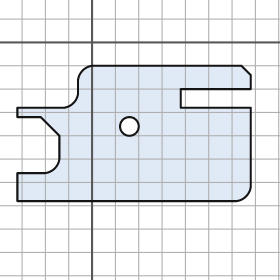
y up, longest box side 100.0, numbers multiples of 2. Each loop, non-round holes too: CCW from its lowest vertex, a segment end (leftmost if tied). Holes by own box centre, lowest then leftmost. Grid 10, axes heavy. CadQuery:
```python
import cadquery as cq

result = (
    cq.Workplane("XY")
    .moveTo(-32.0, -68.0)
    .lineTo(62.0, -68.0)
    .threePointArc((66.0, -66.0), (68.0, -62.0))
    .lineTo(68.0, -28.0)
    .lineTo(38.0, -28.0)
    .lineTo(38.0, -20.0)
    .lineTo(68.0, -20.0)
    .lineTo(68.0, -14.0)
    .lineTo(64.0, -10.0)
    .lineTo(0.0, -10.0)
    .threePointArc((-4.0, -12.0), (-6.0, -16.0))
    .lineTo(-6.0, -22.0)
    .threePointArc((-8.0, -26.0), (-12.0, -28.0))
    .lineTo(-32.0, -28.0)
    .lineTo(-32.0, -32.0)
    .lineTo(-22.0, -32.0)
    .lineTo(-14.0, -40.0)
    .lineTo(-14.0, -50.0)
    .threePointArc((-16.0, -54.0), (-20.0, -56.0))
    .lineTo(-32.0, -56.0)
    .close()
    .moveTo(16.0, -36.0)
    .circle(4.0)
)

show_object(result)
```